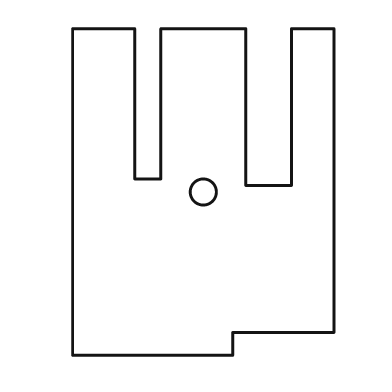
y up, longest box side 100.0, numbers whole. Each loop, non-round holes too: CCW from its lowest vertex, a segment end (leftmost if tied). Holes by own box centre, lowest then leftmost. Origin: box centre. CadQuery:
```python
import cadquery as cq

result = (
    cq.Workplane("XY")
    .moveTo(-40.0, -50.0)
    .lineTo(9.0, -50.0)
    .lineTo(9.0, -43.0)
    .lineTo(40.0, -43.0)
    .lineTo(40.0, 50.0)
    .lineTo(27.0, 50.0)
    .lineTo(27.0, 2.0)
    .lineTo(13.0, 2.0)
    .lineTo(13.0, 50.0)
    .lineTo(-13.0, 50.0)
    .lineTo(-13.0, 4.0)
    .lineTo(-21.0, 4.0)
    .lineTo(-21.0, 50.0)
    .lineTo(-40.0, 50.0)
    .close()
    .moveTo(0.0, 0.0)
    .circle(4.0)
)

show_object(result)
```